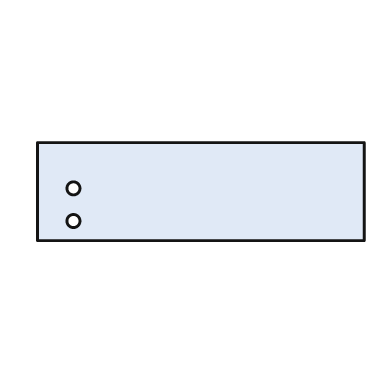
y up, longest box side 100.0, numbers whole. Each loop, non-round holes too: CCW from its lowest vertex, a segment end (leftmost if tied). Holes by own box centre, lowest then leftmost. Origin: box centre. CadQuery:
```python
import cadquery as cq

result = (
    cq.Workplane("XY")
    .moveTo(-50.0, -15.0)
    .lineTo(50.0, -15.0)
    .lineTo(50.0, 15.0)
    .lineTo(-50.0, 15.0)
    .close()
    .moveTo(-39.0, -9.0)
    .circle(2.0)
    .moveTo(-39.0, 1.0)
    .circle(2.0)
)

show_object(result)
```